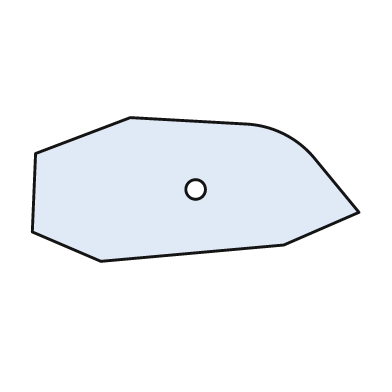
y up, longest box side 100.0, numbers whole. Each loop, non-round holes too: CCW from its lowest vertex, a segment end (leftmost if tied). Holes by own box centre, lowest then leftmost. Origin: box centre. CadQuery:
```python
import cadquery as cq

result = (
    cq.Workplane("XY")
    .moveTo(-29.0, -22.0)
    .lineTo(27.0, -17.0)
    .lineTo(50.0, -7.0)
    .lineTo(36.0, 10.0)
    .threePointArc((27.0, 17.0), (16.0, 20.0))
    .lineTo(-20.0, 22.0)
    .lineTo(-49.0, 11.0)
    .lineTo(-50.0, -13.0)
    .close()
    .moveTo(0.0, 0.0)
    .circle(3.0)
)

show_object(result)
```